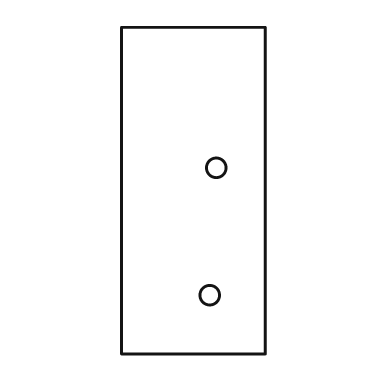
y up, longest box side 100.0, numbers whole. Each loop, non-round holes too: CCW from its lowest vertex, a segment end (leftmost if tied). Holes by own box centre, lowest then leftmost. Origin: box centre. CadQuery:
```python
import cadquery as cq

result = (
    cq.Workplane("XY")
    .moveTo(-22.0, -50.0)
    .lineTo(22.0, -50.0)
    .lineTo(22.0, 50.0)
    .lineTo(-22.0, 50.0)
    .close()
    .moveTo(5.0, -32.0)
    .circle(3.0)
    .moveTo(7.0, 7.0)
    .circle(3.0)
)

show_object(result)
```